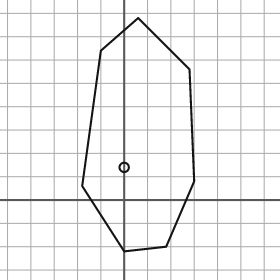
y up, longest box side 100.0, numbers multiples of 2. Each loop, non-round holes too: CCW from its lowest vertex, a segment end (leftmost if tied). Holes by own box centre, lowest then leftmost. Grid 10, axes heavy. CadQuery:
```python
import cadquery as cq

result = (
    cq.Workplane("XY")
    .moveTo(0.0, -22.0)
    .lineTo(18.0, -20.0)
    .lineTo(30.0, 8.0)
    .lineTo(28.0, 56.0)
    .lineTo(6.0, 78.0)
    .lineTo(-10.0, 64.0)
    .lineTo(-18.0, 6.0)
    .close()
    .moveTo(0.0, 14.0)
    .circle(2.0)
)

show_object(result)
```